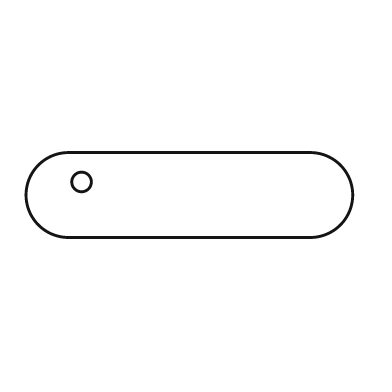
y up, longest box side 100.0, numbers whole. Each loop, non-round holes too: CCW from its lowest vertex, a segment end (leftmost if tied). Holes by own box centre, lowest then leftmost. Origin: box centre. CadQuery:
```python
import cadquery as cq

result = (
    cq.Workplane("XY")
    .moveTo(-37.0, -13.0)
    .lineTo(37.0, -13.0)
    .threePointArc((50.0, 0.0), (37.0, 13.0))
    .lineTo(-37.0, 13.0)
    .threePointArc((-50.0, 0.0), (-37.0, -13.0))
    .close()
    .moveTo(-33.0, 4.0)
    .circle(3.0)
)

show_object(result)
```